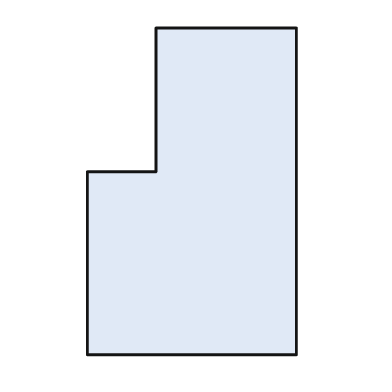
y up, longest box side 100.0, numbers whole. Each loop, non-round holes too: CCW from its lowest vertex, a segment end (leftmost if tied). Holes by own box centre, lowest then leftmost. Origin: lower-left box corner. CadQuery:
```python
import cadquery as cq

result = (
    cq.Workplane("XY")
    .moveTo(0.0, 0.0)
    .lineTo(64.0, 0.0)
    .lineTo(64.0, 100.0)
    .lineTo(21.0, 100.0)
    .lineTo(21.0, 56.0)
    .lineTo(0.0, 56.0)
    .close()
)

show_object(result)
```